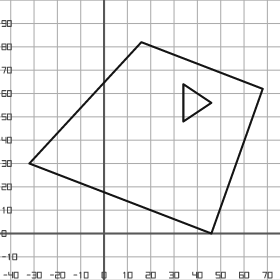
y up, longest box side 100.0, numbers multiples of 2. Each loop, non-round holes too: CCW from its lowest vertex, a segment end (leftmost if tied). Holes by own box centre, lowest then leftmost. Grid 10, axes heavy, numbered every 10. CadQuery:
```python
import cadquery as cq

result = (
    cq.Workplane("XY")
    .moveTo(46.0, 0.0)
    .lineTo(68.0, 62.0)
    .lineTo(16.0, 82.0)
    .lineTo(-32.0, 30.0)
    .close()
    .moveTo(34.0, 48.0)
    .lineTo(46.0, 56.0)
    .lineTo(34.0, 64.0)
    .close()
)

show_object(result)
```